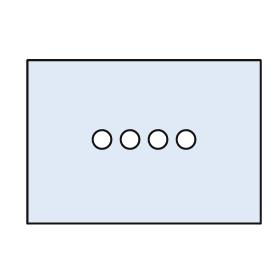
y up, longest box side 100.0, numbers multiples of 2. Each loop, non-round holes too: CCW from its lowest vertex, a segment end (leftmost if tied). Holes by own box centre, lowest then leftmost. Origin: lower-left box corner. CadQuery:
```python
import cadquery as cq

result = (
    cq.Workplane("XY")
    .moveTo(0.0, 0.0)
    .lineTo(100.0, 0.0)
    .lineTo(100.0, 70.0)
    .lineTo(0.0, 70.0)
    .close()
    .moveTo(32.0, 36.0)
    .circle(4.0)
    .moveTo(44.0, 36.0)
    .circle(4.0)
    .moveTo(56.0, 36.0)
    .circle(4.0)
    .moveTo(68.0, 36.0)
    .circle(4.0)
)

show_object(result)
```